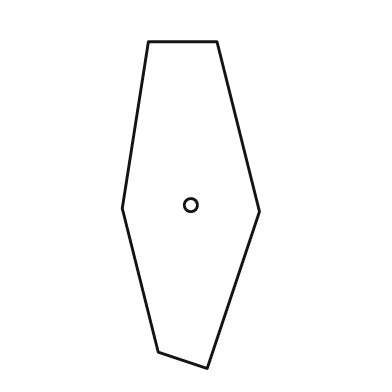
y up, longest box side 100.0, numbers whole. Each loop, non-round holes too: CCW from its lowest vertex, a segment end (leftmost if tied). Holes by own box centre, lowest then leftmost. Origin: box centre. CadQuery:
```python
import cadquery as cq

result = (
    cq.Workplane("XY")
    .moveTo(5.0, -50.0)
    .lineTo(21.0, -2.0)
    .lineTo(8.0, 50.0)
    .lineTo(-13.0, 50.0)
    .lineTo(-21.0, -1.0)
    .lineTo(-10.0, -45.0)
    .close()
    .moveTo(0.0, 0.0)
    .circle(2.0)
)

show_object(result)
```